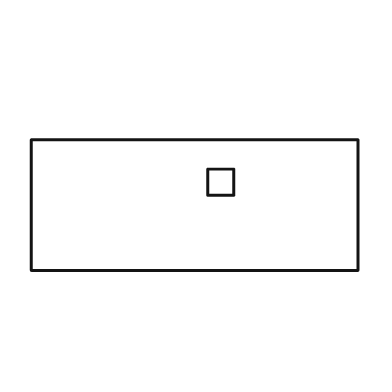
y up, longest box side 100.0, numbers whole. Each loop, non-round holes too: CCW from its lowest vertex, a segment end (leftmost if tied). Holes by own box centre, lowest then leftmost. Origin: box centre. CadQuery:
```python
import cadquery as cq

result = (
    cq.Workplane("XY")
    .moveTo(-50.0, -20.0)
    .lineTo(50.0, -20.0)
    .lineTo(50.0, 20.0)
    .lineTo(-50.0, 20.0)
    .close()
    .moveTo(4.0, 3.0)
    .lineTo(12.0, 3.0)
    .lineTo(12.0, 11.0)
    .lineTo(4.0, 11.0)
    .close()
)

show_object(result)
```